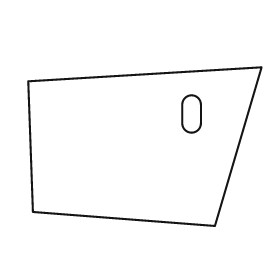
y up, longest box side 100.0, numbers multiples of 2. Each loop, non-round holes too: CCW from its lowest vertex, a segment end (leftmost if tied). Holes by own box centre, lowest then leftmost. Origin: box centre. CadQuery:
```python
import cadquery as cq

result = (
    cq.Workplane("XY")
    .moveTo(30.0, -34.0)
    .lineTo(50.0, 34.0)
    .lineTo(-50.0, 28.0)
    .lineTo(-48.0, -28.0)
    .close()
    .moveTo(16.0, 10.0)
    .threePointArc((20.0, 6.0), (24.0, 10.0))
    .lineTo(24.0, 18.0)
    .threePointArc((20.0, 22.0), (16.0, 18.0))
    .close()
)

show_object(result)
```